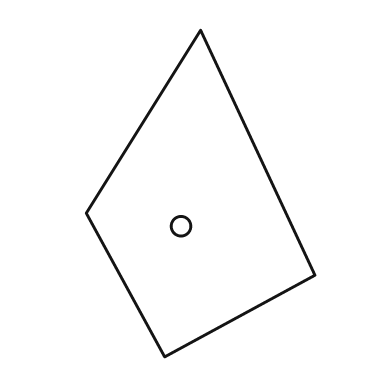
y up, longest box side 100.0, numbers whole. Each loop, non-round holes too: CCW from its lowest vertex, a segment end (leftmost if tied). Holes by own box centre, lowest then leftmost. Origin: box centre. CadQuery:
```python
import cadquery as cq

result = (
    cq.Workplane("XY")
    .moveTo(-11.0, -50.0)
    .lineTo(35.0, -25.0)
    .lineTo(0.0, 50.0)
    .lineTo(-35.0, -6.0)
    .close()
    .moveTo(-6.0, -10.0)
    .circle(3.0)
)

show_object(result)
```